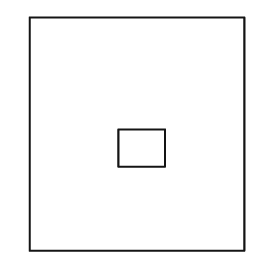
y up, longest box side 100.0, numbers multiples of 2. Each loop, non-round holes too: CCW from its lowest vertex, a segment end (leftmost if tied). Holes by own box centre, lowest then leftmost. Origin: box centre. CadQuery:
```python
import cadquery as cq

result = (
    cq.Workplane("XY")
    .moveTo(-46.0, -50.0)
    .lineTo(46.0, -50.0)
    .lineTo(46.0, 50.0)
    .lineTo(-46.0, 50.0)
    .close()
    .moveTo(-8.0, -14.0)
    .lineTo(12.0, -14.0)
    .lineTo(12.0, 2.0)
    .lineTo(-8.0, 2.0)
    .close()
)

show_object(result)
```